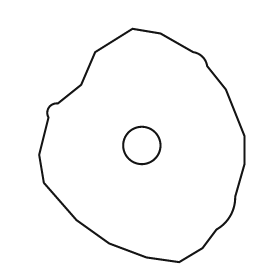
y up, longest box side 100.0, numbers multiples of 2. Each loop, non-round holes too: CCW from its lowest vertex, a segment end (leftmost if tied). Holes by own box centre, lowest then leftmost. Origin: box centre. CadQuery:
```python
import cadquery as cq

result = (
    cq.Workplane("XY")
    .moveTo(16.0, -50.0)
    .lineTo(26.0, -44.0)
    .lineTo(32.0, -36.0)
    .threePointArc((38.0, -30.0), (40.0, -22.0))
    .lineTo(44.0, -8.0)
    .lineTo(44.0, 4.0)
    .lineTo(36.0, 24.0)
    .lineTo(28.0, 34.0)
    .threePointArc((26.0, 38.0), (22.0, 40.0))
    .lineTo(8.0, 48.0)
    .lineTo(-4.0, 50.0)
    .lineTo(-20.0, 40.0)
    .lineTo(-26.0, 26.0)
    .lineTo(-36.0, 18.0)
    .threePointArc((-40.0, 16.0), (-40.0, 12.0))
    .lineTo(-44.0, -4.0)
    .lineTo(-42.0, -16.0)
    .lineTo(-28.0, -32.0)
    .lineTo(-14.0, -42.0)
    .lineTo(2.0, -48.0)
    .close()
    .moveTo(0.0, 0.0)
    .circle(8.0)
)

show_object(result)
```